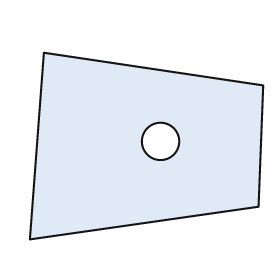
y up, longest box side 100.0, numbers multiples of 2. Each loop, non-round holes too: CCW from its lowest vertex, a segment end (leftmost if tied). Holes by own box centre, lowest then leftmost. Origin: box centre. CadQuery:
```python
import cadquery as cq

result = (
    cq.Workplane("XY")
    .moveTo(-50.0, -40.0)
    .lineTo(48.0, -26.0)
    .lineTo(50.0, 26.0)
    .lineTo(-44.0, 40.0)
    .close()
    .moveTo(6.0, 2.0)
    .circle(8.0)
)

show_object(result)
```